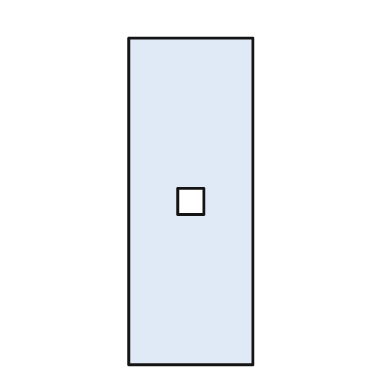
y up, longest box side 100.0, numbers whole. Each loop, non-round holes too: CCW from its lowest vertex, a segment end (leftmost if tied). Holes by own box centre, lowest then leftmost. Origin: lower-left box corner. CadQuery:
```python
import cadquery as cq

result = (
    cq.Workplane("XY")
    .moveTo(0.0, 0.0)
    .lineTo(38.0, 0.0)
    .lineTo(38.0, 100.0)
    .lineTo(0.0, 100.0)
    .close()
    .moveTo(15.0, 46.0)
    .lineTo(23.0, 46.0)
    .lineTo(23.0, 54.0)
    .lineTo(15.0, 54.0)
    .close()
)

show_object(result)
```